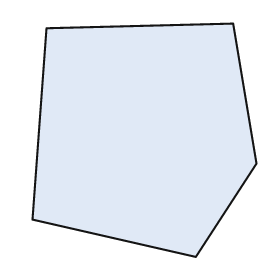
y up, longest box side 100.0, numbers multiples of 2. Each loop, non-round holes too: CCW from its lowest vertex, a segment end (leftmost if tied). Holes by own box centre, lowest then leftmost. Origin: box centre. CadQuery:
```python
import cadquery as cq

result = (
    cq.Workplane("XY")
    .moveTo(22.0, -50.0)
    .lineTo(48.0, -10.0)
    .lineTo(38.0, 50.0)
    .lineTo(-42.0, 48.0)
    .lineTo(-48.0, -34.0)
    .close()
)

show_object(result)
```